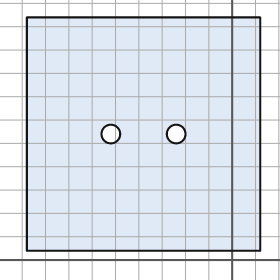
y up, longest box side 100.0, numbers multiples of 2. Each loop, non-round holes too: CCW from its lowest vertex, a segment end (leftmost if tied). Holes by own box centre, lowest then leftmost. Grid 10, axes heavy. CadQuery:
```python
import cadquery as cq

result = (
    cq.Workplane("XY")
    .moveTo(-88.0, 4.0)
    .lineTo(12.0, 4.0)
    .lineTo(12.0, 104.0)
    .lineTo(-88.0, 104.0)
    .close()
    .moveTo(-52.0, 54.0)
    .circle(4.0)
    .moveTo(-24.0, 54.0)
    .circle(4.0)
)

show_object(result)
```